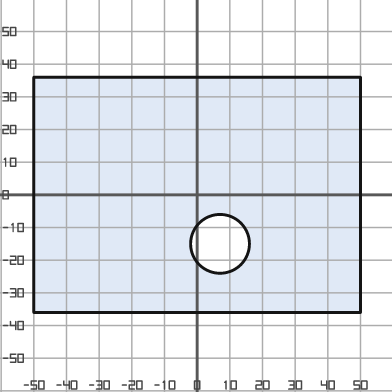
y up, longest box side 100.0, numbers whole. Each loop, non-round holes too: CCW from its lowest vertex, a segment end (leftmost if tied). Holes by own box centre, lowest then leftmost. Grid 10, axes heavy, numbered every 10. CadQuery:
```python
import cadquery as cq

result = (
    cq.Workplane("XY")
    .moveTo(-50.0, -36.0)
    .lineTo(50.0, -36.0)
    .lineTo(50.0, 36.0)
    .lineTo(-50.0, 36.0)
    .close()
    .moveTo(7.0, -15.0)
    .circle(9.0)
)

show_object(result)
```